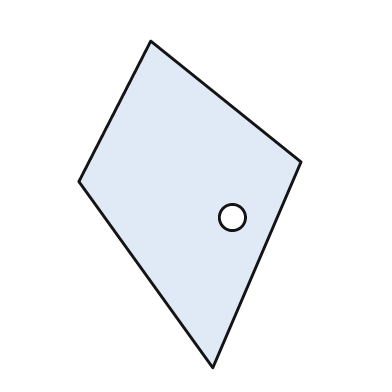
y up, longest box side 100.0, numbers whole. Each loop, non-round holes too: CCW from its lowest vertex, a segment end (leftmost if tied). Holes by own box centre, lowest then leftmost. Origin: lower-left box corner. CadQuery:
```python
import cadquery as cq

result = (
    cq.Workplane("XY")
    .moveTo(41.0, 0.0)
    .lineTo(68.0, 63.0)
    .lineTo(22.0, 100.0)
    .lineTo(0.0, 57.0)
    .close()
    .moveTo(47.0, 46.0)
    .circle(4.0)
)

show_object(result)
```